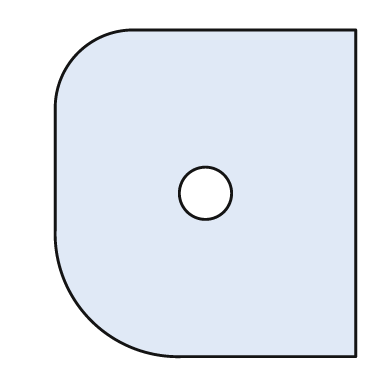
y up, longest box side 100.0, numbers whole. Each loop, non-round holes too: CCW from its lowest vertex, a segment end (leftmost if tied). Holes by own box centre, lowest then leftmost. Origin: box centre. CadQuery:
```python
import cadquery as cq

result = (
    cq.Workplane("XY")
    .moveTo(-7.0, -50.0)
    .lineTo(46.0, -50.0)
    .lineTo(46.0, 50.0)
    .lineTo(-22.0, 50.0)
    .threePointArc((-39.0, 43.0), (-46.0, 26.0))
    .lineTo(-46.0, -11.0)
    .threePointArc((-35.0, -39.0), (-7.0, -50.0))
    .close()
    .moveTo(0.0, 0.0)
    .circle(8.0)
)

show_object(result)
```